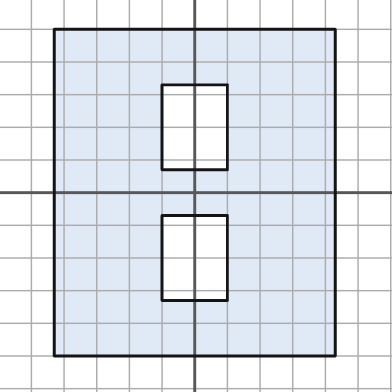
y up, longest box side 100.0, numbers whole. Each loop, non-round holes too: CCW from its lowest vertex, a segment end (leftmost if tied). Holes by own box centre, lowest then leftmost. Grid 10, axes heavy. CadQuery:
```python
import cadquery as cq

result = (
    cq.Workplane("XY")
    .moveTo(-43.0, -50.0)
    .lineTo(43.0, -50.0)
    .lineTo(43.0, 50.0)
    .lineTo(-43.0, 50.0)
    .close()
    .moveTo(-10.0, -33.0)
    .lineTo(10.0, -33.0)
    .lineTo(10.0, -7.0)
    .lineTo(-10.0, -7.0)
    .close()
    .moveTo(-10.0, 7.0)
    .lineTo(10.0, 7.0)
    .lineTo(10.0, 33.0)
    .lineTo(-10.0, 33.0)
    .close()
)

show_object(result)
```